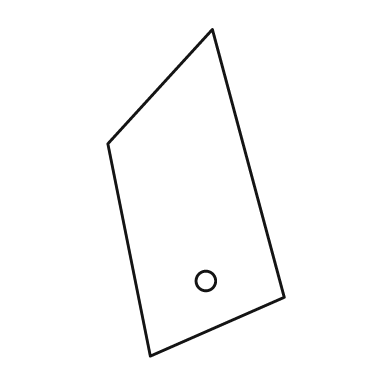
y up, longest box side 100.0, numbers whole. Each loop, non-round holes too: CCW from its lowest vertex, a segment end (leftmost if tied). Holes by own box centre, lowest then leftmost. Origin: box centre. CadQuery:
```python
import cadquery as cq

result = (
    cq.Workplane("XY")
    .moveTo(-14.0, -50.0)
    .lineTo(27.0, -32.0)
    .lineTo(5.0, 50.0)
    .lineTo(-27.0, 15.0)
    .close()
    .moveTo(3.0, -27.0)
    .circle(3.0)
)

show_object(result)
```